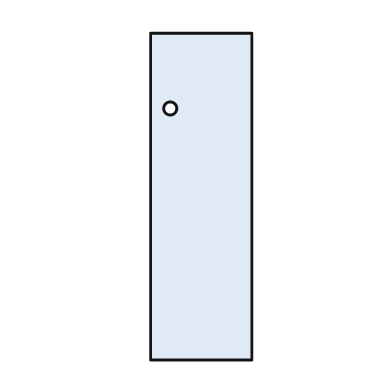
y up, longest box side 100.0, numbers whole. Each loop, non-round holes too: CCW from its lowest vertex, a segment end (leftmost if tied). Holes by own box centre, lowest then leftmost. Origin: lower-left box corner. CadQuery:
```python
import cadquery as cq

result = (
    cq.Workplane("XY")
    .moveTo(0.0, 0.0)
    .lineTo(31.0, 0.0)
    .lineTo(31.0, 100.0)
    .lineTo(0.0, 100.0)
    .close()
    .moveTo(6.0, 77.0)
    .circle(2.0)
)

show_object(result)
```